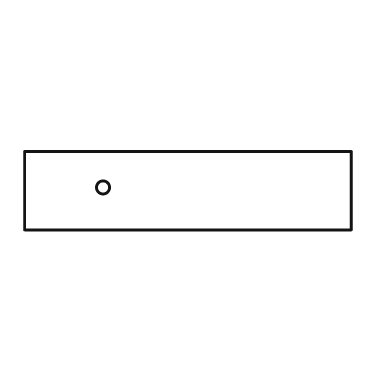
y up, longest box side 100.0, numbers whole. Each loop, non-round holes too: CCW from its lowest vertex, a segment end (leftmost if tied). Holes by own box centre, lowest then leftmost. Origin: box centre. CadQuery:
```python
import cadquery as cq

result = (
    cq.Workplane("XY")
    .moveTo(-50.0, -12.0)
    .lineTo(50.0, -12.0)
    .lineTo(50.0, 12.0)
    .lineTo(-50.0, 12.0)
    .close()
    .moveTo(-26.0, 1.0)
    .circle(2.0)
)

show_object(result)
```